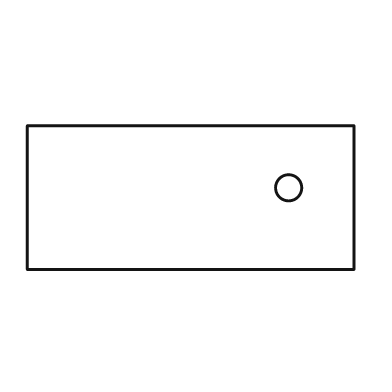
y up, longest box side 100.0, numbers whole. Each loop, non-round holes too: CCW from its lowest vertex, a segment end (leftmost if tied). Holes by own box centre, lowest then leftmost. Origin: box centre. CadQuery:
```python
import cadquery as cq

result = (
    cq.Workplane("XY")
    .moveTo(-50.0, -22.0)
    .lineTo(50.0, -22.0)
    .lineTo(50.0, 22.0)
    .lineTo(-50.0, 22.0)
    .close()
    .moveTo(30.0, 3.0)
    .circle(4.0)
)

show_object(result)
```